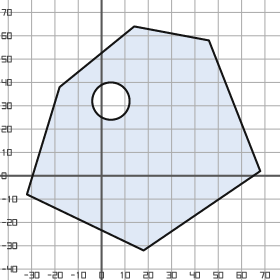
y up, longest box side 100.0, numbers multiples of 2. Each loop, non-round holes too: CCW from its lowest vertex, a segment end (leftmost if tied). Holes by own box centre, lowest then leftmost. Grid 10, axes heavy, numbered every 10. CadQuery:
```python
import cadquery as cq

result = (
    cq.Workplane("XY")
    .moveTo(18.0, -32.0)
    .lineTo(68.0, 2.0)
    .lineTo(46.0, 58.0)
    .lineTo(14.0, 64.0)
    .lineTo(-18.0, 38.0)
    .lineTo(-32.0, -8.0)
    .close()
    .moveTo(4.0, 32.0)
    .circle(8.0)
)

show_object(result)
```